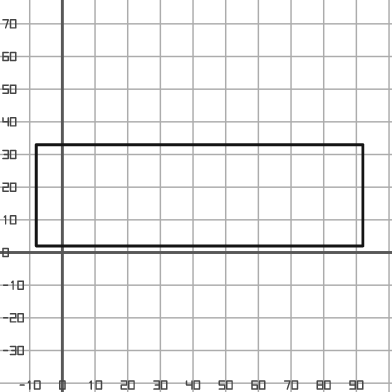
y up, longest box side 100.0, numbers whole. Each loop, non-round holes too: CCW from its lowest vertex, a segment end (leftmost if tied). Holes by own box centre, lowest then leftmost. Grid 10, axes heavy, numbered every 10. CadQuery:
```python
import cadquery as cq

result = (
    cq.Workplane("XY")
    .moveTo(-8.0, 2.0)
    .lineTo(92.0, 2.0)
    .lineTo(92.0, 33.0)
    .lineTo(-8.0, 33.0)
    .close()
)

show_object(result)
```